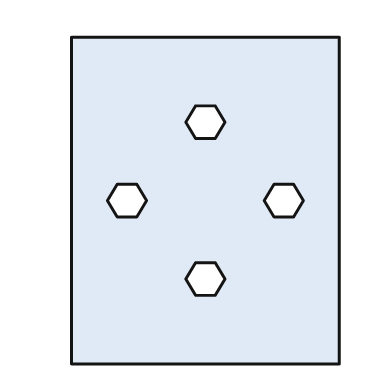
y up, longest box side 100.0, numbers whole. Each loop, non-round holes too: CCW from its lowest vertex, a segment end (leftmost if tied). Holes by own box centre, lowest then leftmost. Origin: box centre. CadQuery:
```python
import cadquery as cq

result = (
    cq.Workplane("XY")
    .moveTo(-41.0, -50.0)
    .lineTo(41.0, -50.0)
    .lineTo(41.0, 50.0)
    .lineTo(-41.0, 50.0)
    .close()
    .moveTo(-3.0, -29.0)
    .lineTo(3.0, -29.0)
    .lineTo(6.0, -24.0)
    .lineTo(3.0, -19.0)
    .lineTo(-3.0, -19.0)
    .lineTo(-6.0, -24.0)
    .close()
    .moveTo(-27.0, -5.0)
    .lineTo(-21.0, -5.0)
    .lineTo(-18.0, 0.0)
    .lineTo(-21.0, 5.0)
    .lineTo(-27.0, 5.0)
    .lineTo(-30.0, 0.0)
    .close()
    .moveTo(21.0, -5.0)
    .lineTo(27.0, -5.0)
    .lineTo(30.0, 0.0)
    .lineTo(27.0, 5.0)
    .lineTo(21.0, 5.0)
    .lineTo(18.0, 0.0)
    .close()
    .moveTo(-3.0, 19.0)
    .lineTo(3.0, 19.0)
    .lineTo(6.0, 24.0)
    .lineTo(3.0, 29.0)
    .lineTo(-3.0, 29.0)
    .lineTo(-6.0, 24.0)
    .close()
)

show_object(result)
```